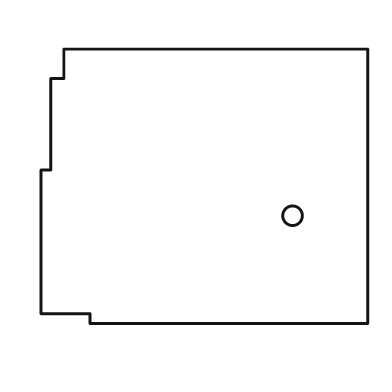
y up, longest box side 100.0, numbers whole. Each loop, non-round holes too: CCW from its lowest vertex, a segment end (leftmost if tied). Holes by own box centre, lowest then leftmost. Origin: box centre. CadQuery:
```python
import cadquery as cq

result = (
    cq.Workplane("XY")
    .moveTo(-35.0, -42.0)
    .lineTo(50.0, -42.0)
    .lineTo(50.0, 42.0)
    .lineTo(-43.0, 42.0)
    .lineTo(-43.0, 33.0)
    .lineTo(-47.0, 33.0)
    .lineTo(-47.0, 5.0)
    .lineTo(-50.0, 5.0)
    .lineTo(-50.0, -39.0)
    .lineTo(-35.0, -39.0)
    .close()
    .moveTo(27.0, -9.0)
    .circle(3.0)
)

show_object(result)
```